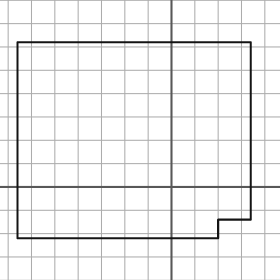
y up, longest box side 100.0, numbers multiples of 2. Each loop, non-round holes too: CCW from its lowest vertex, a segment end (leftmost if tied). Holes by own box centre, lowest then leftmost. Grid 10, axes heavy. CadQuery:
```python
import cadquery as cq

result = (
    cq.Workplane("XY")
    .moveTo(-66.0, -22.0)
    .lineTo(20.0, -22.0)
    .lineTo(20.0, -14.0)
    .lineTo(34.0, -14.0)
    .lineTo(34.0, 62.0)
    .lineTo(-66.0, 62.0)
    .close()
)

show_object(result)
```